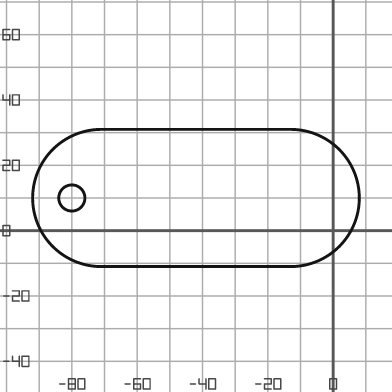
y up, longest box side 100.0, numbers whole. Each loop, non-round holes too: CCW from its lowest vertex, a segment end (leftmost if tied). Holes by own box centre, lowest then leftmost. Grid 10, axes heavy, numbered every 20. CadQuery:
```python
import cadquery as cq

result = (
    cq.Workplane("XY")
    .moveTo(-71.0, -11.0)
    .lineTo(-13.0, -11.0)
    .threePointArc((8.0, 10.0), (-13.0, 31.0))
    .lineTo(-71.0, 31.0)
    .threePointArc((-92.0, 10.0), (-71.0, -11.0))
    .close()
    .moveTo(-80.0, 10.0)
    .circle(4.0)
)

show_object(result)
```